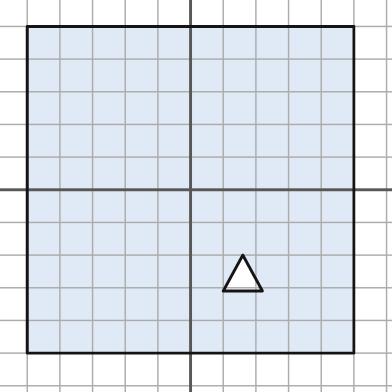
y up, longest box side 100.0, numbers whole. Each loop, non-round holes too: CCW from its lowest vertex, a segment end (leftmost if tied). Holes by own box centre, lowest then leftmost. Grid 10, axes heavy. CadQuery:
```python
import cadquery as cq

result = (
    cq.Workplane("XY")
    .moveTo(-50.0, -50.0)
    .lineTo(50.0, -50.0)
    .lineTo(50.0, 50.0)
    .lineTo(-50.0, 50.0)
    .close()
    .moveTo(10.0, -31.0)
    .lineTo(22.0, -31.0)
    .lineTo(16.0, -20.0)
    .close()
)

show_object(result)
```